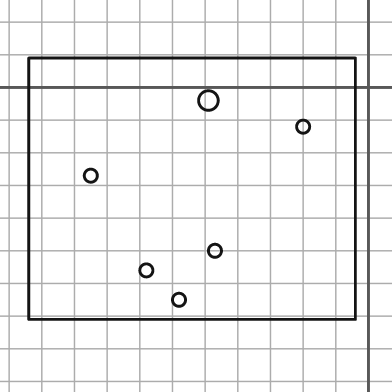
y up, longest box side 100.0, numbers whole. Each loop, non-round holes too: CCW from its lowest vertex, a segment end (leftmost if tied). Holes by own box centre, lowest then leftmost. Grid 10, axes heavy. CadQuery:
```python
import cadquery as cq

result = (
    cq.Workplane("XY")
    .moveTo(-104.0, -71.0)
    .lineTo(-4.0, -71.0)
    .lineTo(-4.0, 9.0)
    .lineTo(-104.0, 9.0)
    .close()
    .moveTo(-58.0, -65.0)
    .circle(2.0)
    .moveTo(-68.0, -56.0)
    .circle(2.0)
    .moveTo(-47.0, -50.0)
    .circle(2.0)
    .moveTo(-85.0, -27.0)
    .circle(2.0)
    .moveTo(-20.0, -12.0)
    .circle(2.0)
    .moveTo(-49.0, -4.0)
    .circle(3.0)
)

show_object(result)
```